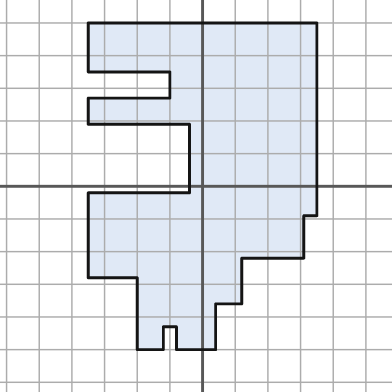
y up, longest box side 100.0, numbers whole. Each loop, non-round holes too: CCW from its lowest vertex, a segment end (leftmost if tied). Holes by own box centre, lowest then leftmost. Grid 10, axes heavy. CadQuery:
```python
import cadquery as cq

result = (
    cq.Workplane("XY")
    .moveTo(-20.0, -50.0)
    .lineTo(-12.0, -50.0)
    .lineTo(-12.0, -43.0)
    .lineTo(-8.0, -43.0)
    .lineTo(-8.0, -50.0)
    .lineTo(4.0, -50.0)
    .lineTo(4.0, -36.0)
    .lineTo(12.0, -36.0)
    .lineTo(12.0, -22.0)
    .lineTo(31.0, -22.0)
    .lineTo(31.0, -9.0)
    .lineTo(35.0, -9.0)
    .lineTo(35.0, 50.0)
    .lineTo(-35.0, 50.0)
    .lineTo(-35.0, 35.0)
    .lineTo(-10.0, 35.0)
    .lineTo(-10.0, 27.0)
    .lineTo(-35.0, 27.0)
    .lineTo(-35.0, 19.0)
    .lineTo(-4.0, 19.0)
    .lineTo(-4.0, -2.0)
    .lineTo(-35.0, -2.0)
    .lineTo(-35.0, -28.0)
    .lineTo(-20.0, -28.0)
    .close()
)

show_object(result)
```